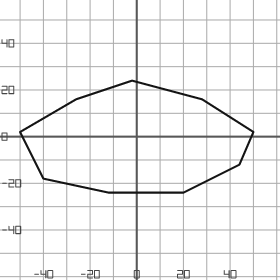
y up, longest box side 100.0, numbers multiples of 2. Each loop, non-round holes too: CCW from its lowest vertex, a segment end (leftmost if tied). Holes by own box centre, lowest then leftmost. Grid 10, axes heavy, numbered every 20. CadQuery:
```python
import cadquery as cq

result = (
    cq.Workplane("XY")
    .moveTo(-12.0, -24.0)
    .lineTo(20.0, -24.0)
    .lineTo(44.0, -12.0)
    .lineTo(50.0, 2.0)
    .lineTo(28.0, 16.0)
    .lineTo(-2.0, 24.0)
    .lineTo(-26.0, 16.0)
    .lineTo(-50.0, 2.0)
    .lineTo(-40.0, -18.0)
    .close()
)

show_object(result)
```